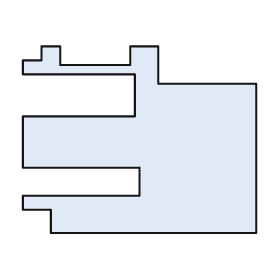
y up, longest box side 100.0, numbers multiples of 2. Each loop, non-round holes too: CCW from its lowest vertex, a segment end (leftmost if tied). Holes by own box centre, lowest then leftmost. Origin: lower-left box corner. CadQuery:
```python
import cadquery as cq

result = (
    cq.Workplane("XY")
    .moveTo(12.0, 0.0)
    .lineTo(100.0, 0.0)
    .lineTo(100.0, 64.0)
    .lineTo(58.0, 64.0)
    .lineTo(58.0, 80.0)
    .lineTo(46.0, 80.0)
    .lineTo(46.0, 72.0)
    .lineTo(16.0, 72.0)
    .lineTo(16.0, 80.0)
    .lineTo(8.0, 80.0)
    .lineTo(8.0, 74.0)
    .lineTo(0.0, 74.0)
    .lineTo(0.0, 68.0)
    .lineTo(48.0, 68.0)
    .lineTo(48.0, 50.0)
    .lineTo(0.0, 50.0)
    .lineTo(0.0, 28.0)
    .lineTo(50.0, 28.0)
    .lineTo(50.0, 16.0)
    .lineTo(0.0, 16.0)
    .lineTo(0.0, 10.0)
    .lineTo(12.0, 10.0)
    .close()
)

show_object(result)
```